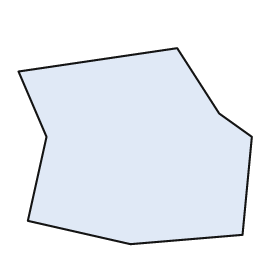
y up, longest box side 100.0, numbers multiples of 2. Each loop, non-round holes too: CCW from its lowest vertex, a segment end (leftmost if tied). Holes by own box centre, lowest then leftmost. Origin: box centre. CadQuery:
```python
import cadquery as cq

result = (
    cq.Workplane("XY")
    .moveTo(-2.0, -42.0)
    .lineTo(46.0, -38.0)
    .lineTo(50.0, 4.0)
    .lineTo(36.0, 14.0)
    .lineTo(18.0, 42.0)
    .lineTo(-50.0, 32.0)
    .lineTo(-38.0, 4.0)
    .lineTo(-46.0, -32.0)
    .close()
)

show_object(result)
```